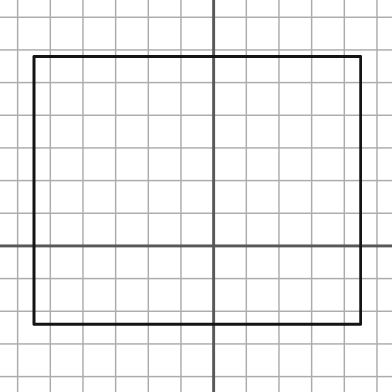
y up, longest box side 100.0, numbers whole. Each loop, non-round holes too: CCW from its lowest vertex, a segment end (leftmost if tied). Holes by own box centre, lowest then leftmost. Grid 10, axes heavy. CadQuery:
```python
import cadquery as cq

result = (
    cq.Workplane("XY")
    .moveTo(-55.0, -24.0)
    .lineTo(45.0, -24.0)
    .lineTo(45.0, 58.0)
    .lineTo(-55.0, 58.0)
    .close()
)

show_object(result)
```